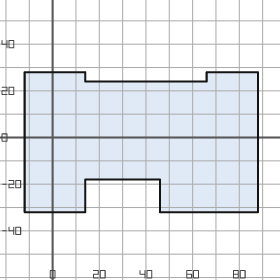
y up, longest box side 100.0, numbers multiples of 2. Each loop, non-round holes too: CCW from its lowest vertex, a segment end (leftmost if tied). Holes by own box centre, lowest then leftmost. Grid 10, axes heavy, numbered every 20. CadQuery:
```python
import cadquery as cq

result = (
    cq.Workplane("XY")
    .moveTo(-12.0, -32.0)
    .lineTo(14.0, -32.0)
    .lineTo(14.0, -18.0)
    .lineTo(46.0, -18.0)
    .lineTo(46.0, -32.0)
    .lineTo(88.0, -32.0)
    .lineTo(88.0, 28.0)
    .lineTo(66.0, 28.0)
    .lineTo(66.0, 24.0)
    .lineTo(14.0, 24.0)
    .lineTo(14.0, 28.0)
    .lineTo(-12.0, 28.0)
    .close()
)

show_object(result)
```